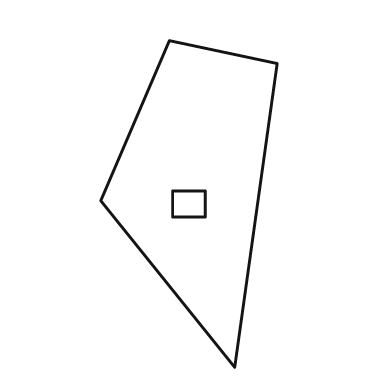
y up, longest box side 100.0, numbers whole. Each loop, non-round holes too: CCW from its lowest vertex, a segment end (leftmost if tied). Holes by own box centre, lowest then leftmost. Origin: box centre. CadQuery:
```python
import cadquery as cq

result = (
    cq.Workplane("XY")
    .moveTo(14.0, -50.0)
    .lineTo(27.0, 43.0)
    .lineTo(-6.0, 50.0)
    .lineTo(-27.0, 1.0)
    .close()
    .moveTo(-5.0, -4.0)
    .lineTo(5.0, -4.0)
    .lineTo(5.0, 4.0)
    .lineTo(-5.0, 4.0)
    .close()
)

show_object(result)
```